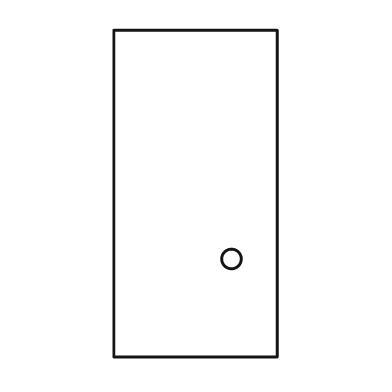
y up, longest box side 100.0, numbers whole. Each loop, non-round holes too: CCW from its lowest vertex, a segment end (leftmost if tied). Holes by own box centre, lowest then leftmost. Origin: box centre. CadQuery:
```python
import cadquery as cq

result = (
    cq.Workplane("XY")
    .moveTo(-25.0, -50.0)
    .lineTo(25.0, -50.0)
    .lineTo(25.0, 50.0)
    .lineTo(-25.0, 50.0)
    .close()
    .moveTo(11.0, -20.0)
    .circle(3.0)
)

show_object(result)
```